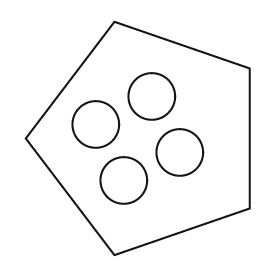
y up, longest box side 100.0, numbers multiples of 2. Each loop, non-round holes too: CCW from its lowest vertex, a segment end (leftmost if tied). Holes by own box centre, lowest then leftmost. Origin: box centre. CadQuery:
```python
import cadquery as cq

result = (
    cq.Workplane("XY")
    .moveTo(-10.0, -50.0)
    .lineTo(48.0, -30.0)
    .lineTo(48.0, 30.0)
    .lineTo(-10.0, 50.0)
    .lineTo(-48.0, 0.0)
    .close()
    .moveTo(-6.0, -18.0)
    .circle(10.0)
    .moveTo(18.0, -6.0)
    .circle(10.0)
    .moveTo(-18.0, 6.0)
    .circle(10.0)
    .moveTo(6.0, 18.0)
    .circle(10.0)
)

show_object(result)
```